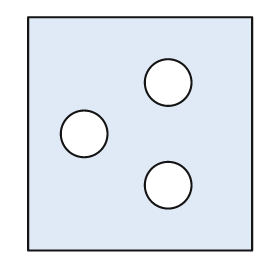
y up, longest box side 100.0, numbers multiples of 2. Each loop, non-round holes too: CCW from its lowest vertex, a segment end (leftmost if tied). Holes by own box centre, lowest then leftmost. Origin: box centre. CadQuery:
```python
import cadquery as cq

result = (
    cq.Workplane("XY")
    .moveTo(-48.0, -50.0)
    .lineTo(48.0, -50.0)
    .lineTo(48.0, 50.0)
    .lineTo(-48.0, 50.0)
    .close()
    .moveTo(12.0, -22.0)
    .circle(10.0)
    .moveTo(-24.0, 0.0)
    .circle(10.0)
    .moveTo(12.0, 22.0)
    .circle(10.0)
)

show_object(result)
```